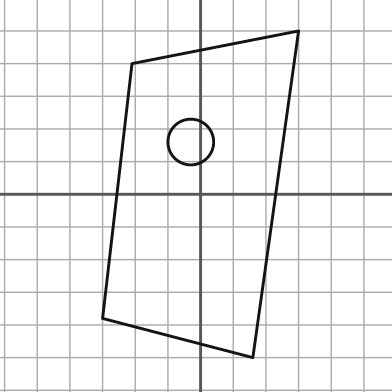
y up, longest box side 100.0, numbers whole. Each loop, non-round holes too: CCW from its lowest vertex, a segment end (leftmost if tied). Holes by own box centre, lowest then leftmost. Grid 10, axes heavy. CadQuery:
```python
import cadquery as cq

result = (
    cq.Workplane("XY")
    .moveTo(16.0, -50.0)
    .lineTo(30.0, 50.0)
    .lineTo(-21.0, 40.0)
    .lineTo(-30.0, -38.0)
    .close()
    .moveTo(-3.0, 16.0)
    .circle(7.0)
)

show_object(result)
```